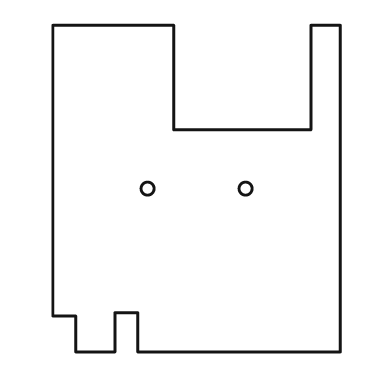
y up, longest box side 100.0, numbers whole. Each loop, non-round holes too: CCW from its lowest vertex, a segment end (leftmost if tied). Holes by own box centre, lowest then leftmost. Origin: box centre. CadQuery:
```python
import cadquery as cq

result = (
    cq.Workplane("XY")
    .moveTo(-37.0, -50.0)
    .lineTo(-25.0, -50.0)
    .lineTo(-25.0, -38.0)
    .lineTo(-18.0, -38.0)
    .lineTo(-18.0, -50.0)
    .lineTo(44.0, -50.0)
    .lineTo(44.0, 50.0)
    .lineTo(35.0, 50.0)
    .lineTo(35.0, 18.0)
    .lineTo(-7.0, 18.0)
    .lineTo(-7.0, 50.0)
    .lineTo(-44.0, 50.0)
    .lineTo(-44.0, -39.0)
    .lineTo(-37.0, -39.0)
    .close()
    .moveTo(-15.0, 0.0)
    .circle(2.0)
    .moveTo(15.0, 0.0)
    .circle(2.0)
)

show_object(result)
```